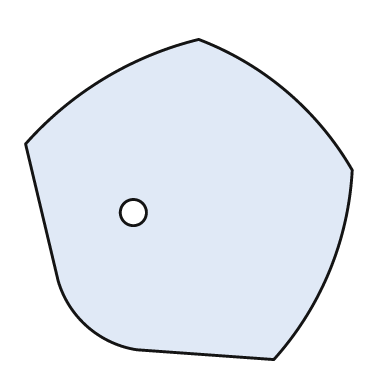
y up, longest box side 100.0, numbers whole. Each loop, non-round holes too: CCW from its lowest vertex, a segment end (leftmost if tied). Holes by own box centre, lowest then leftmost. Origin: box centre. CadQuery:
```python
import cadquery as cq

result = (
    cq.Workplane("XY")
    .moveTo(26.0, -49.0)
    .threePointArc((43.0, -22.0), (50.0, 9.0))
    .threePointArc((30.0, 33.0), (3.0, 49.0))
    .threePointArc((-26.0, 37.0), (-50.0, 17.0))
    .lineTo(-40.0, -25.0)
    .threePointArc((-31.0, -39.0), (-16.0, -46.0))
    .close()
    .moveTo(-17.0, -4.0)
    .circle(4.0)
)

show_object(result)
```